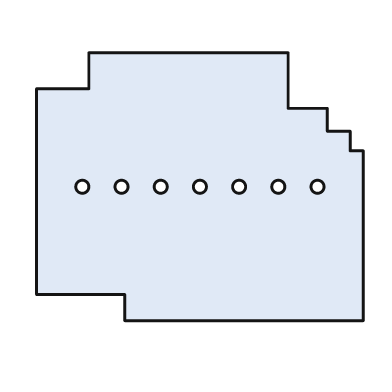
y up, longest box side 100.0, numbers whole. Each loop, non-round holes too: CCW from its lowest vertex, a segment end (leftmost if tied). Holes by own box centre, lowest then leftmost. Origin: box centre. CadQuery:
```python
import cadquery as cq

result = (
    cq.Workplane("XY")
    .moveTo(-23.0, -41.0)
    .lineTo(50.0, -41.0)
    .lineTo(50.0, 11.0)
    .lineTo(46.0, 11.0)
    .lineTo(46.0, 17.0)
    .lineTo(39.0, 17.0)
    .lineTo(39.0, 24.0)
    .lineTo(27.0, 24.0)
    .lineTo(27.0, 41.0)
    .lineTo(-34.0, 41.0)
    .lineTo(-34.0, 30.0)
    .lineTo(-50.0, 30.0)
    .lineTo(-50.0, -33.0)
    .lineTo(-23.0, -33.0)
    .close()
    .moveTo(-36.0, 0.0)
    .circle(2.0)
    .moveTo(-24.0, 0.0)
    .circle(2.0)
    .moveTo(-12.0, 0.0)
    .circle(2.0)
    .moveTo(0.0, 0.0)
    .circle(2.0)
    .moveTo(12.0, 0.0)
    .circle(2.0)
    .moveTo(24.0, 0.0)
    .circle(2.0)
    .moveTo(36.0, 0.0)
    .circle(2.0)
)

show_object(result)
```